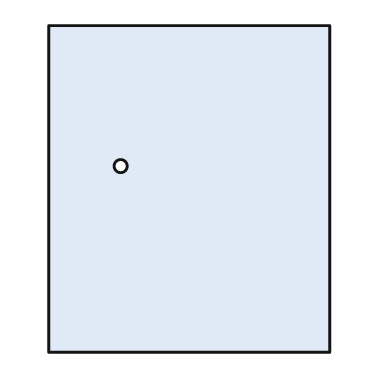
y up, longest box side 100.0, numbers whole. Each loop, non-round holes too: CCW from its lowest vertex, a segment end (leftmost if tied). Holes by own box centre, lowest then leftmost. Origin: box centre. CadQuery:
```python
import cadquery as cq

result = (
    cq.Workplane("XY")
    .moveTo(-43.0, -50.0)
    .lineTo(43.0, -50.0)
    .lineTo(43.0, 50.0)
    .lineTo(-43.0, 50.0)
    .close()
    .moveTo(-21.0, 7.0)
    .circle(2.0)
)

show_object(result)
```